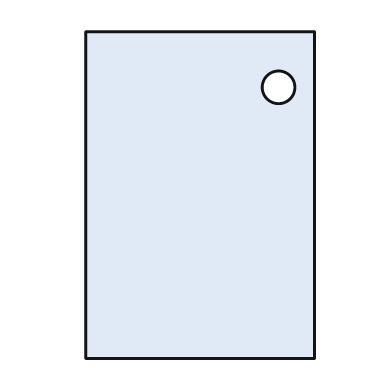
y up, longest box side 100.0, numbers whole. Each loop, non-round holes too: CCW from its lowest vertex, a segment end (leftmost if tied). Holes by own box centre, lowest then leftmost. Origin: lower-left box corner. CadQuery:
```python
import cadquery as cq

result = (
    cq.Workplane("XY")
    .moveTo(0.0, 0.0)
    .lineTo(70.0, 0.0)
    .lineTo(70.0, 100.0)
    .lineTo(0.0, 100.0)
    .close()
    .moveTo(59.0, 83.0)
    .circle(5.0)
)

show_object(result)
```